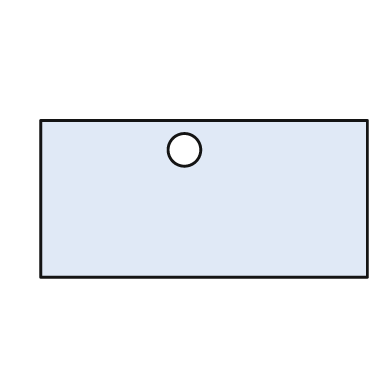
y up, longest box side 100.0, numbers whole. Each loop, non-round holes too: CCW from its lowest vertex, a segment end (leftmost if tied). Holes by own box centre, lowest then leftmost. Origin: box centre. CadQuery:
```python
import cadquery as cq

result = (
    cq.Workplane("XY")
    .moveTo(-50.0, -24.0)
    .lineTo(50.0, -24.0)
    .lineTo(50.0, 24.0)
    .lineTo(-50.0, 24.0)
    .close()
    .moveTo(-6.0, 15.0)
    .circle(5.0)
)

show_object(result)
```